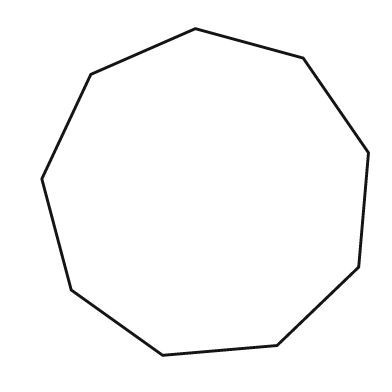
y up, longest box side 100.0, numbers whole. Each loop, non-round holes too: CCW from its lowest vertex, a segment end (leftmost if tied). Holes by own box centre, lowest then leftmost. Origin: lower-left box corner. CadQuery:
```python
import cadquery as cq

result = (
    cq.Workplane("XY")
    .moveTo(37.0, 0.0)
    .lineTo(72.0, 3.0)
    .lineTo(97.0, 27.0)
    .lineTo(100.0, 62.0)
    .lineTo(80.0, 91.0)
    .lineTo(47.0, 100.0)
    .lineTo(15.0, 86.0)
    .lineTo(0.0, 54.0)
    .lineTo(9.0, 20.0)
    .close()
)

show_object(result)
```